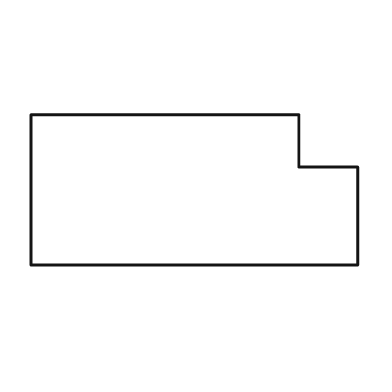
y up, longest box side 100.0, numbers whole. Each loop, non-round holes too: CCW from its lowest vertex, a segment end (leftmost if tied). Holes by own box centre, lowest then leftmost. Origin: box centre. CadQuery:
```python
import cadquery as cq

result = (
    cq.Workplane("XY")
    .moveTo(-50.0, -23.0)
    .lineTo(50.0, -23.0)
    .lineTo(50.0, 7.0)
    .lineTo(32.0, 7.0)
    .lineTo(32.0, 23.0)
    .lineTo(-50.0, 23.0)
    .close()
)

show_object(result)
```